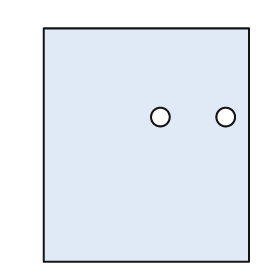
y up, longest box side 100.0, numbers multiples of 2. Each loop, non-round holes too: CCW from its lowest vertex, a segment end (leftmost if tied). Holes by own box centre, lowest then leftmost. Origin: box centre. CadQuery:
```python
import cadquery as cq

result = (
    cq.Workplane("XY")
    .moveTo(-44.0, -50.0)
    .lineTo(44.0, -50.0)
    .lineTo(44.0, 50.0)
    .lineTo(-44.0, 50.0)
    .close()
    .moveTo(6.0, 12.0)
    .circle(4.0)
    .moveTo(34.0, 12.0)
    .circle(4.0)
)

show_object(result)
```